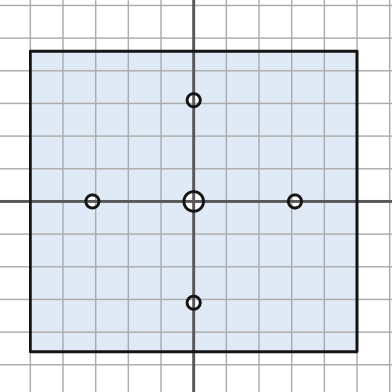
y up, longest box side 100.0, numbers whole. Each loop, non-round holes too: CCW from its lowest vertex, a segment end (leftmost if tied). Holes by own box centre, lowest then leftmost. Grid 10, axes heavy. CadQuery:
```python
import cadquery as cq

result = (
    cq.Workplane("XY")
    .moveTo(-50.0, -46.0)
    .lineTo(50.0, -46.0)
    .lineTo(50.0, 46.0)
    .lineTo(-50.0, 46.0)
    .close()
    .moveTo(0.0, -31.0)
    .circle(2.0)
    .moveTo(-31.0, 0.0)
    .circle(2.0)
    .moveTo(0.0, 0.0)
    .circle(3.0)
    .moveTo(31.0, 0.0)
    .circle(2.0)
    .moveTo(0.0, 31.0)
    .circle(2.0)
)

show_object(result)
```